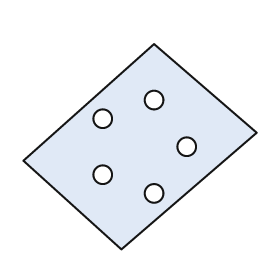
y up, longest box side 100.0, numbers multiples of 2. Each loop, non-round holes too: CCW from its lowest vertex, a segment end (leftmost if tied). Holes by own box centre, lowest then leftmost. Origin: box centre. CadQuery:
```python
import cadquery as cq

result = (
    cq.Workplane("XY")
    .moveTo(-8.0, -44.0)
    .lineTo(50.0, 6.0)
    .lineTo(6.0, 44.0)
    .lineTo(-50.0, -6.0)
    .close()
    .moveTo(6.0, -20.0)
    .circle(4.0)
    .moveTo(-16.0, -12.0)
    .circle(4.0)
    .moveTo(20.0, 0.0)
    .circle(4.0)
    .moveTo(-16.0, 12.0)
    .circle(4.0)
    .moveTo(6.0, 20.0)
    .circle(4.0)
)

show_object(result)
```